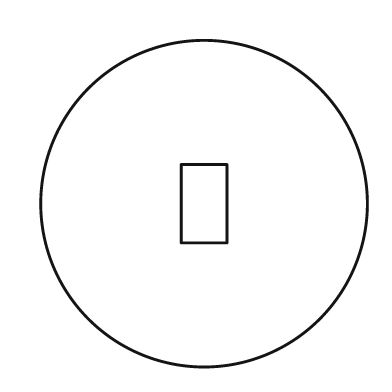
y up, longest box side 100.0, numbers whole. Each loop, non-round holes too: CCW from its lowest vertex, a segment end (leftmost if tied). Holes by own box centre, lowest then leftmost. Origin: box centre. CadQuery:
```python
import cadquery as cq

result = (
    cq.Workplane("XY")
    .moveTo(0.0, 0.0)
    .circle(50.0)
    .moveTo(-7.0, -12.0)
    .lineTo(7.0, -12.0)
    .lineTo(7.0, 12.0)
    .lineTo(-7.0, 12.0)
    .close()
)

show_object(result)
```